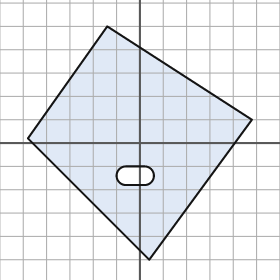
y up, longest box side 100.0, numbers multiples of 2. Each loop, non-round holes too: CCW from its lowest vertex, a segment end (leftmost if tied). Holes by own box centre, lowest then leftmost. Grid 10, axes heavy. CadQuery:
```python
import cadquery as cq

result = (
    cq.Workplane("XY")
    .moveTo(4.0, -50.0)
    .lineTo(48.0, 10.0)
    .lineTo(-14.0, 50.0)
    .lineTo(-48.0, 2.0)
    .close()
    .moveTo(-6.0, -18.0)
    .lineTo(2.0, -18.0)
    .threePointArc((6.0, -14.0), (2.0, -10.0))
    .lineTo(-6.0, -10.0)
    .threePointArc((-10.0, -14.0), (-6.0, -18.0))
    .close()
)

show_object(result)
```